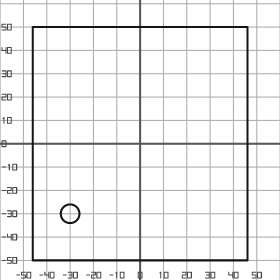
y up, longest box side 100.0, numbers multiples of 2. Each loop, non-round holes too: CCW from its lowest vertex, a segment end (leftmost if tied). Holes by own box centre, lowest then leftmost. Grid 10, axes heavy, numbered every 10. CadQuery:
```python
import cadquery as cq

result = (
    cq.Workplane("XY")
    .moveTo(-46.0, -50.0)
    .lineTo(46.0, -50.0)
    .lineTo(46.0, 50.0)
    .lineTo(-46.0, 50.0)
    .close()
    .moveTo(-30.0, -30.0)
    .circle(4.0)
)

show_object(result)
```